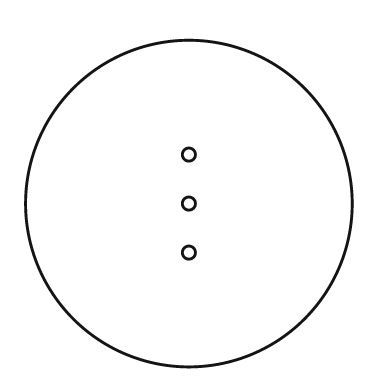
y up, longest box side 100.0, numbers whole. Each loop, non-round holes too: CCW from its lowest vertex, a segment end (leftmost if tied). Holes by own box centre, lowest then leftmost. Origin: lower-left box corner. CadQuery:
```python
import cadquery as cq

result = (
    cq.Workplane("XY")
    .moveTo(50.0, 50.0)
    .circle(50.0)
    .moveTo(50.0, 35.0)
    .circle(2.0)
    .moveTo(50.0, 50.0)
    .circle(2.0)
    .moveTo(50.0, 65.0)
    .circle(2.0)
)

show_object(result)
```